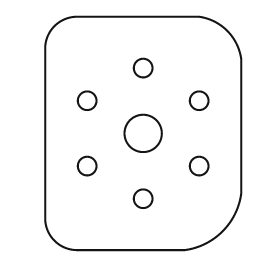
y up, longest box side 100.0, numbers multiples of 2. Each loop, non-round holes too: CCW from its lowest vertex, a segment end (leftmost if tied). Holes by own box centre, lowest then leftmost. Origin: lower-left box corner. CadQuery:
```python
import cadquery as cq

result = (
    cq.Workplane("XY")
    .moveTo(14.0, 0.0)
    .lineTo(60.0, 0.0)
    .threePointArc((76.0, 8.0), (84.0, 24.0))
    .lineTo(84.0, 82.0)
    .threePointArc((78.0, 94.0), (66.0, 100.0))
    .lineTo(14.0, 100.0)
    .threePointArc((4.0, 96.0), (0.0, 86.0))
    .lineTo(0.0, 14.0)
    .threePointArc((4.0, 4.0), (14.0, 0.0))
    .close()
    .moveTo(42.0, 22.0)
    .circle(4.0)
    .moveTo(18.0, 36.0)
    .circle(4.0)
    .moveTo(66.0, 36.0)
    .circle(4.0)
    .moveTo(42.0, 50.0)
    .circle(8.0)
    .moveTo(18.0, 64.0)
    .circle(4.0)
    .moveTo(66.0, 64.0)
    .circle(4.0)
    .moveTo(42.0, 78.0)
    .circle(4.0)
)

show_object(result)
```